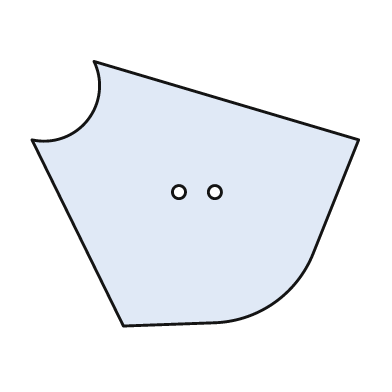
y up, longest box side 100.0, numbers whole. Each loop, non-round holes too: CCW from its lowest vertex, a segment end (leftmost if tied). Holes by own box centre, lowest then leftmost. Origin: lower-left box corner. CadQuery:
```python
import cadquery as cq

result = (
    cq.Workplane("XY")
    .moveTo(28.0, 0.0)
    .lineTo(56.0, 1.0)
    .threePointArc((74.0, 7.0), (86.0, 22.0))
    .lineTo(100.0, 57.0)
    .lineTo(19.0, 81.0)
    .threePointArc((17.0, 63.0), (0.0, 57.0))
    .close()
    .moveTo(45.0, 41.0)
    .circle(2.0)
    .moveTo(56.0, 41.0)
    .circle(2.0)
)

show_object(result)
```